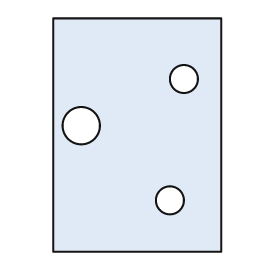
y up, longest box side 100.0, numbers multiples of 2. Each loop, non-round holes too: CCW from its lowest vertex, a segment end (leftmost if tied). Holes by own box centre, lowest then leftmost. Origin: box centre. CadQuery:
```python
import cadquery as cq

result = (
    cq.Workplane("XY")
    .moveTo(-36.0, -50.0)
    .lineTo(36.0, -50.0)
    .lineTo(36.0, 50.0)
    .lineTo(-36.0, 50.0)
    .close()
    .moveTo(14.0, -28.0)
    .circle(6.0)
    .moveTo(-24.0, 4.0)
    .circle(8.0)
    .moveTo(20.0, 24.0)
    .circle(6.0)
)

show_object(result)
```